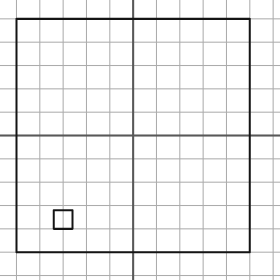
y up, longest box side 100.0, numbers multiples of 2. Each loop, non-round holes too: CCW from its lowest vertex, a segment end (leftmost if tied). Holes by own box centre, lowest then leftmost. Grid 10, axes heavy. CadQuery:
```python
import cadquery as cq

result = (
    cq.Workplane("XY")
    .moveTo(-50.0, -50.0)
    .lineTo(50.0, -50.0)
    .lineTo(50.0, 50.0)
    .lineTo(-50.0, 50.0)
    .close()
    .moveTo(-34.0, -40.0)
    .lineTo(-26.0, -40.0)
    .lineTo(-26.0, -32.0)
    .lineTo(-34.0, -32.0)
    .close()
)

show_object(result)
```